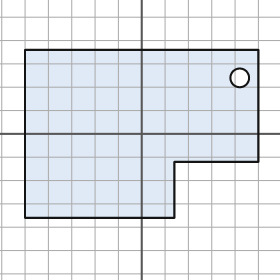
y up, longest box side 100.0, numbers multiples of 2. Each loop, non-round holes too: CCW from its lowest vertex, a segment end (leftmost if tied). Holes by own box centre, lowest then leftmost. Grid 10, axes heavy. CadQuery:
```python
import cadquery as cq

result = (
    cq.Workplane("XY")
    .moveTo(-50.0, -36.0)
    .lineTo(14.0, -36.0)
    .lineTo(14.0, -12.0)
    .lineTo(50.0, -12.0)
    .lineTo(50.0, 36.0)
    .lineTo(-50.0, 36.0)
    .close()
    .moveTo(42.0, 24.0)
    .circle(4.0)
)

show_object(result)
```